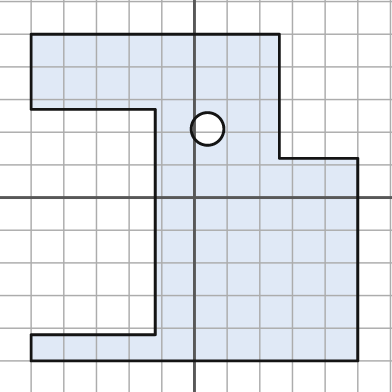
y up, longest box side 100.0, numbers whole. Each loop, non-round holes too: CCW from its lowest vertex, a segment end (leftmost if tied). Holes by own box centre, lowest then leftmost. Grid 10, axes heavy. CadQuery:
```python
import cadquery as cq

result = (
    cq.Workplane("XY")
    .moveTo(-50.0, -50.0)
    .lineTo(50.0, -50.0)
    .lineTo(50.0, 12.0)
    .lineTo(26.0, 12.0)
    .lineTo(26.0, 50.0)
    .lineTo(-50.0, 50.0)
    .lineTo(-50.0, 27.0)
    .lineTo(-12.0, 27.0)
    .lineTo(-12.0, -42.0)
    .lineTo(-50.0, -42.0)
    .close()
    .moveTo(4.0, 21.0)
    .circle(5.0)
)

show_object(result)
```